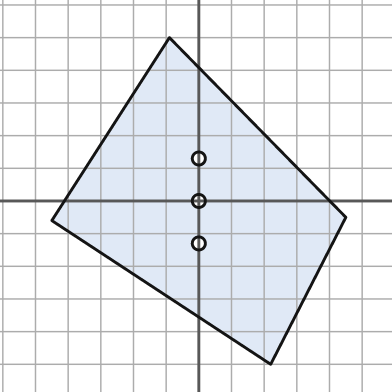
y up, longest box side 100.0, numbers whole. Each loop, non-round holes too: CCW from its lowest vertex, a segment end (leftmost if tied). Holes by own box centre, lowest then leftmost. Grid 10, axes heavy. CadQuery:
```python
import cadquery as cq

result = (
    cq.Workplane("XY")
    .moveTo(22.0, -50.0)
    .lineTo(45.0, -5.0)
    .lineTo(-9.0, 50.0)
    .lineTo(-45.0, -6.0)
    .close()
    .moveTo(0.0, -13.0)
    .circle(2.0)
    .moveTo(0.0, 0.0)
    .circle(2.0)
    .moveTo(0.0, 13.0)
    .circle(2.0)
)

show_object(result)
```